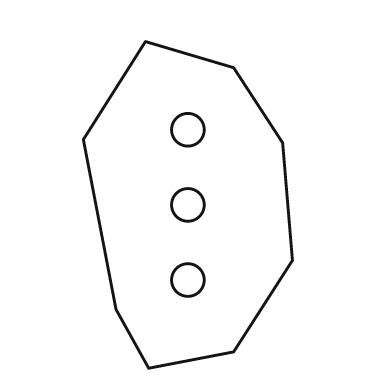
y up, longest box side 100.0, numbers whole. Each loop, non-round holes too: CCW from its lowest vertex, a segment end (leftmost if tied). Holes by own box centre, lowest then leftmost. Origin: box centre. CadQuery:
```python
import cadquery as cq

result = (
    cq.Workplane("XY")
    .moveTo(-12.0, -50.0)
    .lineTo(14.0, -45.0)
    .lineTo(32.0, -17.0)
    .lineTo(29.0, 19.0)
    .lineTo(14.0, 42.0)
    .lineTo(-13.0, 50.0)
    .lineTo(-32.0, 20.0)
    .lineTo(-22.0, -32.0)
    .close()
    .moveTo(0.0, -23.0)
    .circle(5.0)
    .moveTo(0.0, 0.0)
    .circle(5.0)
    .moveTo(0.0, 23.0)
    .circle(5.0)
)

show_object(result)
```